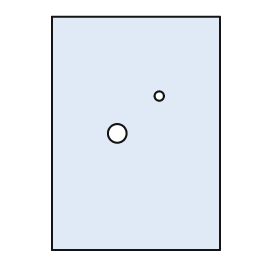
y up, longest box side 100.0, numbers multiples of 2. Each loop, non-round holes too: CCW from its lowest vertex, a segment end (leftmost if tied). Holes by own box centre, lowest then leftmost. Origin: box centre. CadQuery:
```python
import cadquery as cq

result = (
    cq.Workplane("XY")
    .moveTo(-36.0, -50.0)
    .lineTo(36.0, -50.0)
    .lineTo(36.0, 50.0)
    .lineTo(-36.0, 50.0)
    .close()
    .moveTo(-8.0, 0.0)
    .circle(4.0)
    .moveTo(10.0, 16.0)
    .circle(2.0)
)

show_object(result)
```